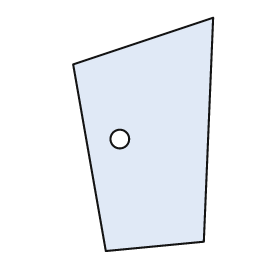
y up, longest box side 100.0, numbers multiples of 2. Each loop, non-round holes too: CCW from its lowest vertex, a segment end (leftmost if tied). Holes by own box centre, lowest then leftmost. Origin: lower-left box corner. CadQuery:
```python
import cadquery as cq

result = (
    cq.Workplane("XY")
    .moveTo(14.0, 0.0)
    .lineTo(56.0, 4.0)
    .lineTo(60.0, 100.0)
    .lineTo(0.0, 80.0)
    .close()
    .moveTo(20.0, 48.0)
    .circle(4.0)
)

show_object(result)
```